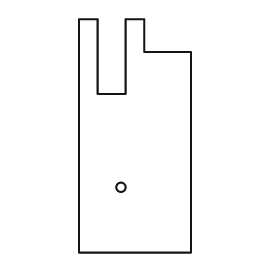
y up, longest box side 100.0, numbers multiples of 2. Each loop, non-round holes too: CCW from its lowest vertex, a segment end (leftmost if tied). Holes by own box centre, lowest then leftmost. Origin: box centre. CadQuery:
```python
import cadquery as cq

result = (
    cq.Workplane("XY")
    .moveTo(-24.0, -50.0)
    .lineTo(24.0, -50.0)
    .lineTo(24.0, 36.0)
    .lineTo(4.0, 36.0)
    .lineTo(4.0, 50.0)
    .lineTo(-4.0, 50.0)
    .lineTo(-4.0, 18.0)
    .lineTo(-16.0, 18.0)
    .lineTo(-16.0, 50.0)
    .lineTo(-24.0, 50.0)
    .close()
    .moveTo(-6.0, -22.0)
    .circle(2.0)
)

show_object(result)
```